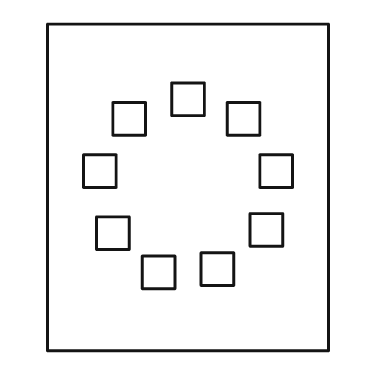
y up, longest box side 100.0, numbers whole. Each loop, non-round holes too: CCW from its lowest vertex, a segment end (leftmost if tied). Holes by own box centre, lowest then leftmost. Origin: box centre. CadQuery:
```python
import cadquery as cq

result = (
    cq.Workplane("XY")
    .moveTo(-43.0, -50.0)
    .lineTo(43.0, -50.0)
    .lineTo(43.0, 50.0)
    .lineTo(-43.0, 50.0)
    .close()
    .moveTo(-14.0, -31.0)
    .lineTo(-4.0, -31.0)
    .lineTo(-4.0, -21.0)
    .lineTo(-14.0, -21.0)
    .close()
    .moveTo(4.0, -30.0)
    .lineTo(14.0, -30.0)
    .lineTo(14.0, -20.0)
    .lineTo(4.0, -20.0)
    .close()
    .moveTo(-28.0, -19.0)
    .lineTo(-18.0, -19.0)
    .lineTo(-18.0, -9.0)
    .lineTo(-28.0, -9.0)
    .close()
    .moveTo(19.0, -18.0)
    .lineTo(29.0, -18.0)
    .lineTo(29.0, -8.0)
    .lineTo(19.0, -8.0)
    .close()
    .moveTo(-32.0, 0.0)
    .lineTo(-22.0, 0.0)
    .lineTo(-22.0, 10.0)
    .lineTo(-32.0, 10.0)
    .close()
    .moveTo(22.0, 0.0)
    .lineTo(32.0, 0.0)
    .lineTo(32.0, 10.0)
    .lineTo(22.0, 10.0)
    .close()
    .moveTo(-23.0, 16.0)
    .lineTo(-13.0, 16.0)
    .lineTo(-13.0, 26.0)
    .lineTo(-23.0, 26.0)
    .close()
    .moveTo(12.0, 16.0)
    .lineTo(22.0, 16.0)
    .lineTo(22.0, 26.0)
    .lineTo(12.0, 26.0)
    .close()
    .moveTo(-5.0, 22.0)
    .lineTo(5.0, 22.0)
    .lineTo(5.0, 32.0)
    .lineTo(-5.0, 32.0)
    .close()
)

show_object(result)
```